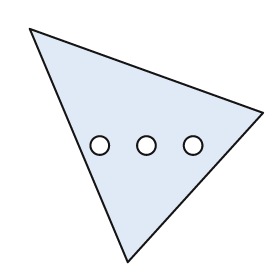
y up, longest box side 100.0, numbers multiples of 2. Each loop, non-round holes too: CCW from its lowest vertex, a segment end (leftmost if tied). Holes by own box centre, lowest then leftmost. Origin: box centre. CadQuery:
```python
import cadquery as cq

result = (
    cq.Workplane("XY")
    .moveTo(-8.0, -50.0)
    .lineTo(50.0, 14.0)
    .lineTo(-50.0, 50.0)
    .close()
    .moveTo(-20.0, 0.0)
    .circle(4.0)
    .moveTo(0.0, 0.0)
    .circle(4.0)
    .moveTo(20.0, 0.0)
    .circle(4.0)
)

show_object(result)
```